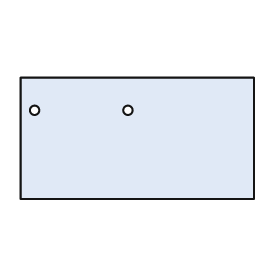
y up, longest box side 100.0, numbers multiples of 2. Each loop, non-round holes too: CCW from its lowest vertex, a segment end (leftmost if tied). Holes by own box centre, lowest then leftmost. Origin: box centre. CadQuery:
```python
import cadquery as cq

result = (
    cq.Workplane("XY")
    .moveTo(-50.0, -26.0)
    .lineTo(50.0, -26.0)
    .lineTo(50.0, 26.0)
    .lineTo(-50.0, 26.0)
    .close()
    .moveTo(-44.0, 12.0)
    .circle(2.0)
    .moveTo(-4.0, 12.0)
    .circle(2.0)
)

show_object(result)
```